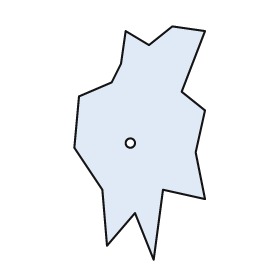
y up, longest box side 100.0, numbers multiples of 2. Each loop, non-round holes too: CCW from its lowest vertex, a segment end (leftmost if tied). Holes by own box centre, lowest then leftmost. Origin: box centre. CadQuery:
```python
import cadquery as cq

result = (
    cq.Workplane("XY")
    .moveTo(6.0, -50.0)
    .lineTo(10.0, -20.0)
    .lineTo(28.0, -24.0)
    .lineTo(24.0, -4.0)
    .lineTo(28.0, 14.0)
    .lineTo(18.0, 22.0)
    .lineTo(28.0, 48.0)
    .lineTo(14.0, 50.0)
    .lineTo(4.0, 42.0)
    .lineTo(-6.0, 48.0)
    .lineTo(-8.0, 34.0)
    .lineTo(-12.0, 26.0)
    .lineTo(-26.0, 20.0)
    .lineTo(-28.0, -2.0)
    .lineTo(-16.0, -20.0)
    .lineTo(-14.0, -44.0)
    .lineTo(-2.0, -30.0)
    .close()
    .moveTo(-4.0, 0.0)
    .circle(2.0)
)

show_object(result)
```